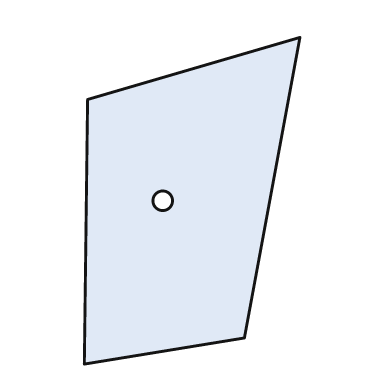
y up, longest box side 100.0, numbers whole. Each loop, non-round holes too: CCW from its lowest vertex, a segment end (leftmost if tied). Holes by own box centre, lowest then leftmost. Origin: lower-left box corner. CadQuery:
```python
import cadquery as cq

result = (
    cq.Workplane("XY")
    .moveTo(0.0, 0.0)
    .lineTo(49.0, 8.0)
    .lineTo(66.0, 100.0)
    .lineTo(1.0, 81.0)
    .close()
    .moveTo(24.0, 50.0)
    .circle(3.0)
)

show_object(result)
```